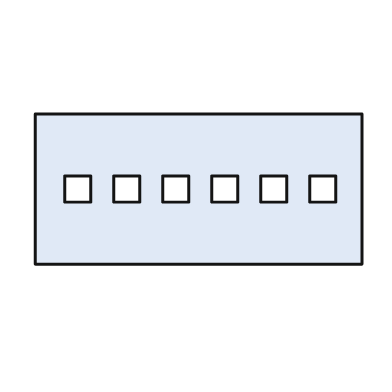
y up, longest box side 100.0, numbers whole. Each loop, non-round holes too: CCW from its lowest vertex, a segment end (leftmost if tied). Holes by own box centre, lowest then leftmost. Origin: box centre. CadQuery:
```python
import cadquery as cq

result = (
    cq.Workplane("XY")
    .moveTo(-50.0, -23.0)
    .lineTo(50.0, -23.0)
    .lineTo(50.0, 23.0)
    .lineTo(-50.0, 23.0)
    .close()
    .moveTo(-41.0, -4.0)
    .lineTo(-33.0, -4.0)
    .lineTo(-33.0, 4.0)
    .lineTo(-41.0, 4.0)
    .close()
    .moveTo(-26.0, -4.0)
    .lineTo(-18.0, -4.0)
    .lineTo(-18.0, 4.0)
    .lineTo(-26.0, 4.0)
    .close()
    .moveTo(-11.0, -4.0)
    .lineTo(-3.0, -4.0)
    .lineTo(-3.0, 4.0)
    .lineTo(-11.0, 4.0)
    .close()
    .moveTo(4.0, -4.0)
    .lineTo(12.0, -4.0)
    .lineTo(12.0, 4.0)
    .lineTo(4.0, 4.0)
    .close()
    .moveTo(19.0, -4.0)
    .lineTo(27.0, -4.0)
    .lineTo(27.0, 4.0)
    .lineTo(19.0, 4.0)
    .close()
    .moveTo(34.0, -4.0)
    .lineTo(42.0, -4.0)
    .lineTo(42.0, 4.0)
    .lineTo(34.0, 4.0)
    .close()
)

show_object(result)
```